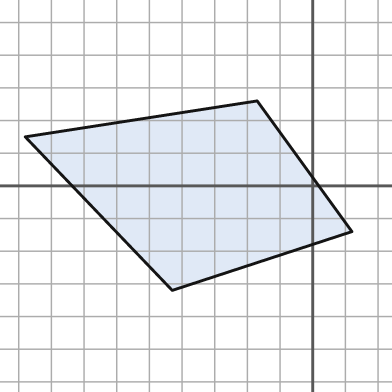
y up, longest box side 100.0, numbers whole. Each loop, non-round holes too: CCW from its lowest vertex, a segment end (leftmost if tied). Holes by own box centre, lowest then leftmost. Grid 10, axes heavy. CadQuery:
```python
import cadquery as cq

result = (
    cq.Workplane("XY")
    .moveTo(-43.0, -32.0)
    .lineTo(12.0, -14.0)
    .lineTo(-17.0, 26.0)
    .lineTo(-88.0, 15.0)
    .close()
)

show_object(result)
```